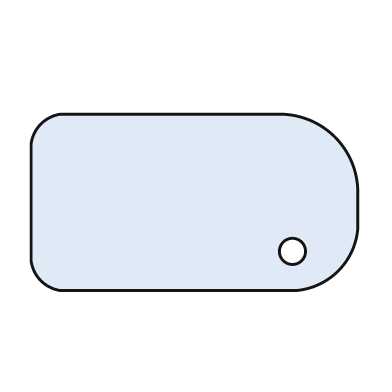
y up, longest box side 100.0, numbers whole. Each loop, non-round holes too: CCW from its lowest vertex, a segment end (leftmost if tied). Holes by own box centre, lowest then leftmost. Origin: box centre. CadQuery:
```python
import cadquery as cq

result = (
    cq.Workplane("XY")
    .moveTo(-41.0, -27.0)
    .lineTo(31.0, -27.0)
    .threePointArc((44.0, -21.0), (50.0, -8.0))
    .lineTo(50.0, 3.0)
    .threePointArc((43.0, 20.0), (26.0, 27.0))
    .lineTo(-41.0, 27.0)
    .threePointArc((-47.0, 24.0), (-50.0, 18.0))
    .lineTo(-50.0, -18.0)
    .threePointArc((-47.0, -24.0), (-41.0, -27.0))
    .close()
    .moveTo(30.0, -15.0)
    .circle(4.0)
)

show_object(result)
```